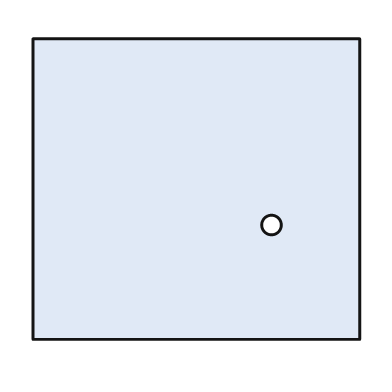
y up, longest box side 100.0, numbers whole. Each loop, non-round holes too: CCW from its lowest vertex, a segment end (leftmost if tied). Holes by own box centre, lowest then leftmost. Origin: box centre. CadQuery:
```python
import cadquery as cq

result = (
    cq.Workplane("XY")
    .moveTo(-50.0, -46.0)
    .lineTo(50.0, -46.0)
    .lineTo(50.0, 46.0)
    .lineTo(-50.0, 46.0)
    .close()
    .moveTo(23.0, -11.0)
    .circle(3.0)
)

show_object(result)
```